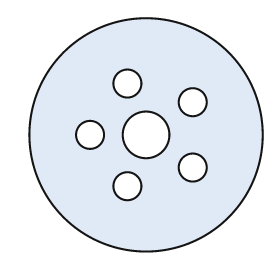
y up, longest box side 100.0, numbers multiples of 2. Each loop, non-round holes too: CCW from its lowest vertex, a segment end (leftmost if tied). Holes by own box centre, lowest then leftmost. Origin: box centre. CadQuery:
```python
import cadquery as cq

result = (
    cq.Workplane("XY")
    .moveTo(0.0, 0.0)
    .circle(50.0)
    .moveTo(-8.0, -22.0)
    .circle(6.0)
    .moveTo(20.0, -14.0)
    .circle(6.0)
    .moveTo(-24.0, 0.0)
    .circle(6.0)
    .moveTo(0.0, 0.0)
    .circle(10.0)
    .moveTo(20.0, 14.0)
    .circle(6.0)
    .moveTo(-8.0, 22.0)
    .circle(6.0)
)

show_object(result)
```